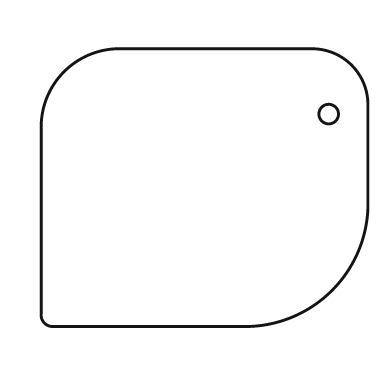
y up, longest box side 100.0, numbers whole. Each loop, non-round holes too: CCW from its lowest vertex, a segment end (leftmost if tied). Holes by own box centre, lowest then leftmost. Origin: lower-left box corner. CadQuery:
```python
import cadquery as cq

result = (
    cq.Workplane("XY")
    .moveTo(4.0, 0.0)
    .lineTo(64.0, 0.0)
    .threePointArc((89.0, 11.0), (100.0, 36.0))
    .lineTo(100.0, 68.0)
    .threePointArc((95.0, 80.0), (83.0, 85.0))
    .lineTo(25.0, 85.0)
    .threePointArc((7.0, 78.0), (0.0, 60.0))
    .lineTo(0.0, 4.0)
    .threePointArc((1.0, 1.0), (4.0, 0.0))
    .close()
    .moveTo(88.0, 65.0)
    .circle(3.0)
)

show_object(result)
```